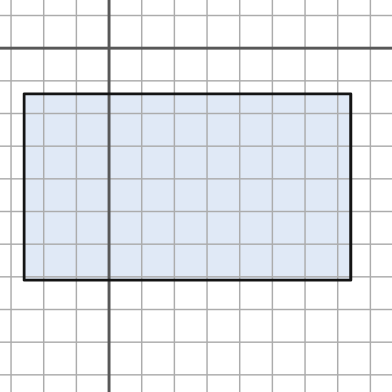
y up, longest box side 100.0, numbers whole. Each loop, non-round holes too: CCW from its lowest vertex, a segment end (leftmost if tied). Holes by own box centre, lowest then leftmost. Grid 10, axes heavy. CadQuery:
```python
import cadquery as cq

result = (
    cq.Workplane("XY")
    .moveTo(-26.0, -71.0)
    .lineTo(74.0, -71.0)
    .lineTo(74.0, -14.0)
    .lineTo(-26.0, -14.0)
    .close()
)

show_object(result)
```